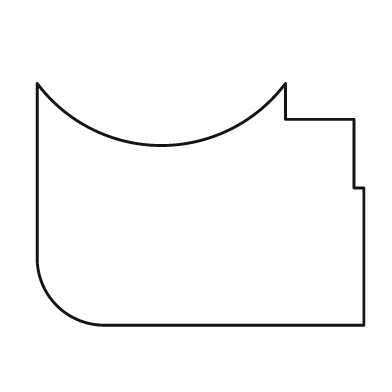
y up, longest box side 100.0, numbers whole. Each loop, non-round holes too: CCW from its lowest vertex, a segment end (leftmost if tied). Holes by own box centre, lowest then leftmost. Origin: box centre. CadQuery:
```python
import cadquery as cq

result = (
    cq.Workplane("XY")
    .moveTo(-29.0, -37.0)
    .lineTo(50.0, -37.0)
    .lineTo(50.0, 5.0)
    .lineTo(47.0, 5.0)
    .lineTo(47.0, 26.0)
    .lineTo(26.0, 26.0)
    .lineTo(26.0, 37.0)
    .threePointArc((-12.0, 18.0), (-50.0, 37.0))
    .lineTo(-50.0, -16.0)
    .threePointArc((-44.0, -31.0), (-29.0, -37.0))
    .close()
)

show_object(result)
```